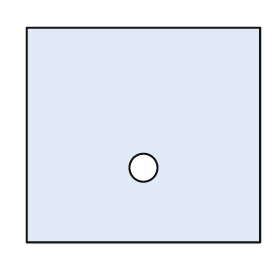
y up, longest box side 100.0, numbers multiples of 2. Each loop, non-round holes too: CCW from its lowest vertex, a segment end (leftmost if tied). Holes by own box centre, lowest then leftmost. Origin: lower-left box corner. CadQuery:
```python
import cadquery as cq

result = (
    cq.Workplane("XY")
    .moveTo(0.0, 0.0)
    .lineTo(100.0, 0.0)
    .lineTo(100.0, 92.0)
    .lineTo(0.0, 92.0)
    .close()
    .moveTo(50.0, 32.0)
    .circle(6.0)
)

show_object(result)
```